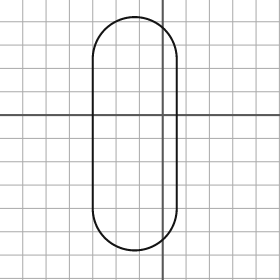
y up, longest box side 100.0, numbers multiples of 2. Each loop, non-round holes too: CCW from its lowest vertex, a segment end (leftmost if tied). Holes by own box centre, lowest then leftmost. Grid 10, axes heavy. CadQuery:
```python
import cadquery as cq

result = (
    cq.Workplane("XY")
    .moveTo(-30.0, -40.0)
    .threePointArc((-12.0, -58.0), (6.0, -40.0))
    .lineTo(6.0, 24.0)
    .threePointArc((-12.0, 42.0), (-30.0, 24.0))
    .close()
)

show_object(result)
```